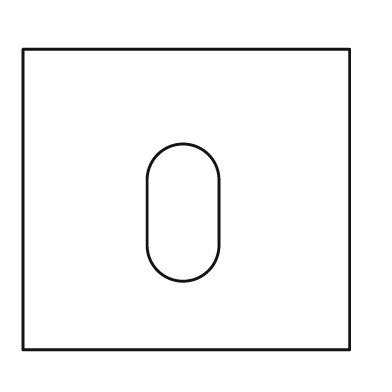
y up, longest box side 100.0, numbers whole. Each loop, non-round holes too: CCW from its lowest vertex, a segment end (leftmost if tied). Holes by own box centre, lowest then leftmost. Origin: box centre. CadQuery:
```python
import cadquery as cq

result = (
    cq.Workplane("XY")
    .moveTo(-50.0, -46.0)
    .lineTo(50.0, -46.0)
    .lineTo(50.0, 46.0)
    .lineTo(-50.0, 46.0)
    .close()
    .moveTo(-12.0, -14.0)
    .threePointArc((-1.0, -25.0), (10.0, -14.0))
    .lineTo(10.0, 6.0)
    .threePointArc((-1.0, 17.0), (-12.0, 6.0))
    .close()
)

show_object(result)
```